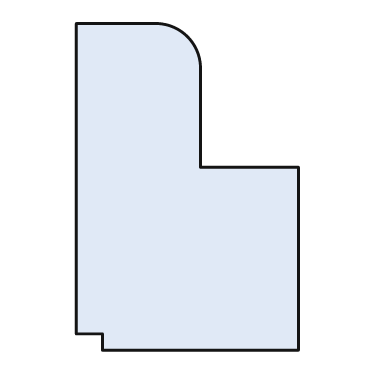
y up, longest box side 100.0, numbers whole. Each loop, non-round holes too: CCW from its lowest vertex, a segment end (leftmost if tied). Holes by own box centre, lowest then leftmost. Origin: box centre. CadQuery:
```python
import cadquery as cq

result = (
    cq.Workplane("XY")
    .moveTo(-26.0, -50.0)
    .lineTo(34.0, -50.0)
    .lineTo(34.0, 6.0)
    .lineTo(4.0, 6.0)
    .lineTo(4.0, 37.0)
    .threePointArc((0.0, 46.0), (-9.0, 50.0))
    .lineTo(-34.0, 50.0)
    .lineTo(-34.0, -45.0)
    .lineTo(-26.0, -45.0)
    .close()
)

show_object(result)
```